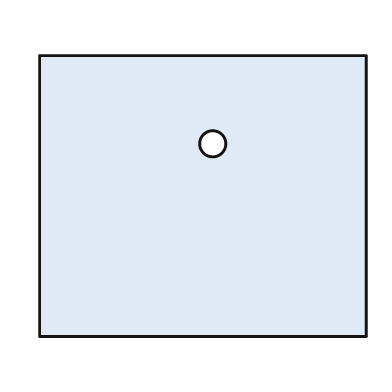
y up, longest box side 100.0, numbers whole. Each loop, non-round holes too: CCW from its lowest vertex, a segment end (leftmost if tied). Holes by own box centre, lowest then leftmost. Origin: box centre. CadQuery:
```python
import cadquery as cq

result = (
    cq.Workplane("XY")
    .moveTo(-50.0, -43.0)
    .lineTo(50.0, -43.0)
    .lineTo(50.0, 43.0)
    .lineTo(-50.0, 43.0)
    .close()
    .moveTo(3.0, 16.0)
    .circle(4.0)
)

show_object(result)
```